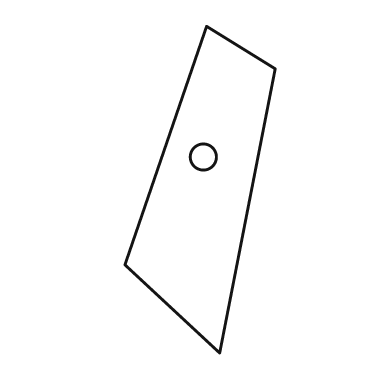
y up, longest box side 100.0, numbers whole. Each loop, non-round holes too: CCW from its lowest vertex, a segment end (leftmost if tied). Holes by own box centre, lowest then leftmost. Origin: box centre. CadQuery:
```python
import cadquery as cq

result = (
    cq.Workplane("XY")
    .moveTo(6.0, -50.0)
    .lineTo(23.0, 37.0)
    .lineTo(2.0, 50.0)
    .lineTo(-23.0, -23.0)
    .close()
    .moveTo(1.0, 10.0)
    .circle(4.0)
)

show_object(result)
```